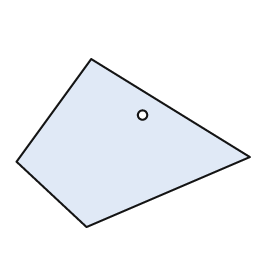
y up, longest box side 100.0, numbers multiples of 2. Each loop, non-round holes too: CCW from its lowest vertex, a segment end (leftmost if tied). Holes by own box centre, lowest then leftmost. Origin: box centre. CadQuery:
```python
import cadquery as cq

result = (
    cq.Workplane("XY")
    .moveTo(-20.0, -36.0)
    .lineTo(50.0, -6.0)
    .lineTo(-18.0, 36.0)
    .lineTo(-50.0, -8.0)
    .close()
    .moveTo(4.0, 12.0)
    .circle(2.0)
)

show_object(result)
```